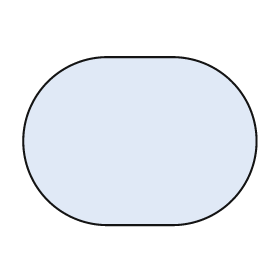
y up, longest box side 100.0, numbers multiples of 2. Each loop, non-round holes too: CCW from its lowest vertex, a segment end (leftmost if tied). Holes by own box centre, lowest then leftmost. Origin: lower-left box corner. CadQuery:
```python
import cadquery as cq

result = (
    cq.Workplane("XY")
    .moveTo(36.0, 0.0)
    .lineTo(64.0, 0.0)
    .threePointArc((100.0, 36.0), (64.0, 72.0))
    .lineTo(36.0, 72.0)
    .threePointArc((0.0, 36.0), (36.0, 0.0))
    .close()
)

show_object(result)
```